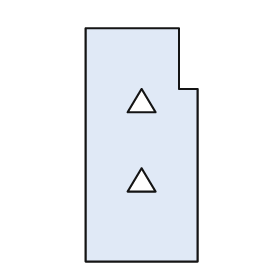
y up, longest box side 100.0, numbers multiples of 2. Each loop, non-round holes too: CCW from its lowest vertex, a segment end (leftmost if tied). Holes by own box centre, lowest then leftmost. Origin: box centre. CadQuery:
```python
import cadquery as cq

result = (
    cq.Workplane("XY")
    .moveTo(-24.0, -50.0)
    .lineTo(24.0, -50.0)
    .lineTo(24.0, 24.0)
    .lineTo(16.0, 24.0)
    .lineTo(16.0, 50.0)
    .lineTo(-24.0, 50.0)
    .close()
    .moveTo(-6.0, -20.0)
    .lineTo(6.0, -20.0)
    .lineTo(0.0, -10.0)
    .close()
    .moveTo(-6.0, 14.0)
    .lineTo(6.0, 14.0)
    .lineTo(0.0, 24.0)
    .close()
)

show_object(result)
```